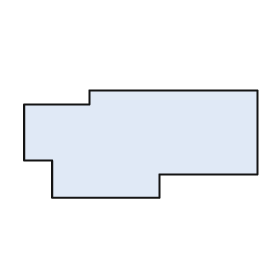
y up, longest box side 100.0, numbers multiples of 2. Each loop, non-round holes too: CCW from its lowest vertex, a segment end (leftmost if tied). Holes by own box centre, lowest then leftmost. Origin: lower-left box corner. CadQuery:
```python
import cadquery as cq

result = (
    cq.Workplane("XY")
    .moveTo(12.0, 0.0)
    .lineTo(58.0, 0.0)
    .lineTo(58.0, 10.0)
    .lineTo(100.0, 10.0)
    .lineTo(100.0, 46.0)
    .lineTo(28.0, 46.0)
    .lineTo(28.0, 40.0)
    .lineTo(0.0, 40.0)
    .lineTo(0.0, 16.0)
    .lineTo(12.0, 16.0)
    .close()
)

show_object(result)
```